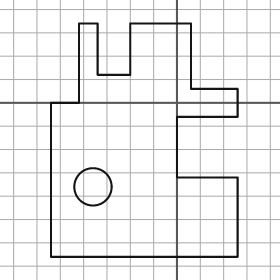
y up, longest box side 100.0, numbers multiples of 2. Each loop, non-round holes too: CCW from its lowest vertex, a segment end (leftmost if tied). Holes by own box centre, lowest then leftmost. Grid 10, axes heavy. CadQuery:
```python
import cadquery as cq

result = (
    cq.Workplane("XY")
    .moveTo(-54.0, -66.0)
    .lineTo(26.0, -66.0)
    .lineTo(26.0, -32.0)
    .lineTo(0.0, -32.0)
    .lineTo(0.0, -6.0)
    .lineTo(26.0, -6.0)
    .lineTo(26.0, 6.0)
    .lineTo(6.0, 6.0)
    .lineTo(6.0, 34.0)
    .lineTo(-20.0, 34.0)
    .lineTo(-20.0, 12.0)
    .lineTo(-34.0, 12.0)
    .lineTo(-34.0, 34.0)
    .lineTo(-42.0, 34.0)
    .lineTo(-42.0, 0.0)
    .lineTo(-54.0, 0.0)
    .close()
    .moveTo(-36.0, -36.0)
    .circle(8.0)
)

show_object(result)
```